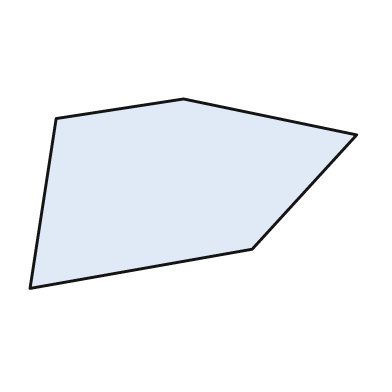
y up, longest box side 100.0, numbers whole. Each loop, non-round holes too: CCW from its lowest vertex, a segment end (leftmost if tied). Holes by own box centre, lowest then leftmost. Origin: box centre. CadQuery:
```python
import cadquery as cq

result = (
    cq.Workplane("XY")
    .moveTo(-50.0, -29.0)
    .lineTo(18.0, -17.0)
    .lineTo(50.0, 18.0)
    .lineTo(-3.0, 29.0)
    .lineTo(-42.0, 23.0)
    .close()
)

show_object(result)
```